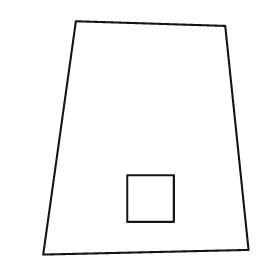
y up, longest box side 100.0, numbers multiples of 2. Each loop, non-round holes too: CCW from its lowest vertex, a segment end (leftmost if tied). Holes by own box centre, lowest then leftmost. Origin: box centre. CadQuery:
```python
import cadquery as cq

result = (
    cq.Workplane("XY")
    .moveTo(-44.0, -50.0)
    .lineTo(44.0, -48.0)
    .lineTo(34.0, 48.0)
    .lineTo(-30.0, 50.0)
    .close()
    .moveTo(-8.0, -36.0)
    .lineTo(12.0, -36.0)
    .lineTo(12.0, -16.0)
    .lineTo(-8.0, -16.0)
    .close()
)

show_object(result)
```